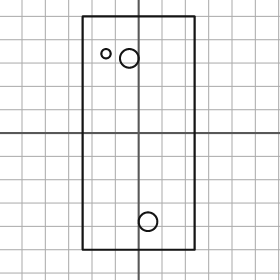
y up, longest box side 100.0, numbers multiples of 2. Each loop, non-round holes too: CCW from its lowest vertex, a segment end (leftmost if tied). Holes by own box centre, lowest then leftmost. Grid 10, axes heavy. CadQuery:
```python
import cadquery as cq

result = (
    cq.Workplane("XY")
    .moveTo(-24.0, -50.0)
    .lineTo(24.0, -50.0)
    .lineTo(24.0, 50.0)
    .lineTo(-24.0, 50.0)
    .close()
    .moveTo(4.0, -38.0)
    .circle(4.0)
    .moveTo(-4.0, 32.0)
    .circle(4.0)
    .moveTo(-14.0, 34.0)
    .circle(2.0)
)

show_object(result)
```